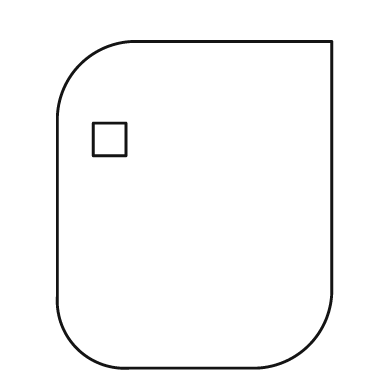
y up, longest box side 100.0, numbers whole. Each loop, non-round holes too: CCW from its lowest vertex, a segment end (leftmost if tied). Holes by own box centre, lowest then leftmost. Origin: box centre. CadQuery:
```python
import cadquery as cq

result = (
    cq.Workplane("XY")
    .moveTo(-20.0, -50.0)
    .lineTo(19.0, -50.0)
    .threePointArc((35.0, -43.0), (42.0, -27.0))
    .lineTo(42.0, 50.0)
    .lineTo(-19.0, 50.0)
    .threePointArc((-35.0, 43.0), (-42.0, 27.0))
    .lineTo(-42.0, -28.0)
    .threePointArc((-36.0, -44.0), (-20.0, -50.0))
    .close()
    .moveTo(-31.0, 15.0)
    .lineTo(-21.0, 15.0)
    .lineTo(-21.0, 25.0)
    .lineTo(-31.0, 25.0)
    .close()
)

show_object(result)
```